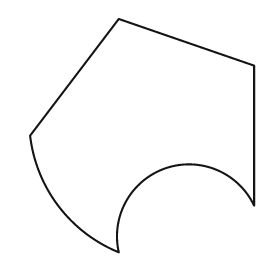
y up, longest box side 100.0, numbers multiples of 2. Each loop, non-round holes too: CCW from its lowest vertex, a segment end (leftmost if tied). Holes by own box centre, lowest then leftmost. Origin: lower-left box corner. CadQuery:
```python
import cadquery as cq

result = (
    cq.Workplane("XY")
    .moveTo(38.0, 0.0)
    .threePointArc((58.0, 36.0), (96.0, 20.0))
    .lineTo(96.0, 80.0)
    .lineTo(38.0, 100.0)
    .lineTo(0.0, 50.0)
    .threePointArc((12.0, 20.0), (38.0, 0.0))
    .close()
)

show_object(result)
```